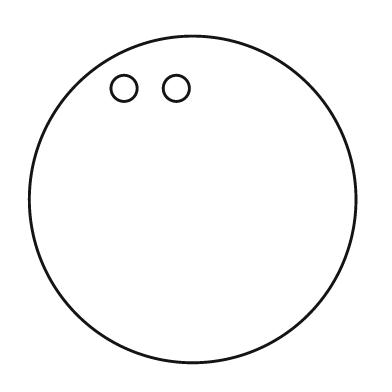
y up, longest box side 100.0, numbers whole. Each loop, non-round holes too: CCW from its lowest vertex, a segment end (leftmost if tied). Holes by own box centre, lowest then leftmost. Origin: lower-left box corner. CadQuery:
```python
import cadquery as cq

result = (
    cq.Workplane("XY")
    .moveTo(50.0, 50.0)
    .circle(50.0)
    .moveTo(29.0, 84.0)
    .circle(4.0)
    .moveTo(45.0, 84.0)
    .circle(4.0)
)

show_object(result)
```